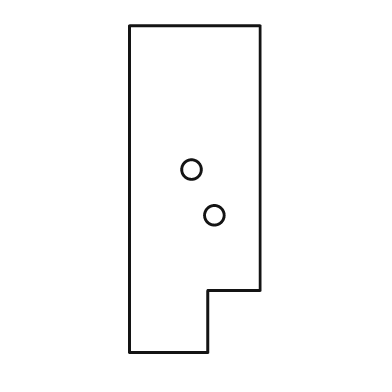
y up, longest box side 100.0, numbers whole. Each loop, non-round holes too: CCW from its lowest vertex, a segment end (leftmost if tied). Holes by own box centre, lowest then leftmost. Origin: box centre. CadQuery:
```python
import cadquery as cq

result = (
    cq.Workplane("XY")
    .moveTo(-20.0, -50.0)
    .lineTo(4.0, -50.0)
    .lineTo(4.0, -31.0)
    .lineTo(20.0, -31.0)
    .lineTo(20.0, 50.0)
    .lineTo(-20.0, 50.0)
    .close()
    .moveTo(6.0, -8.0)
    .circle(3.0)
    .moveTo(-1.0, 6.0)
    .circle(3.0)
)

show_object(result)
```